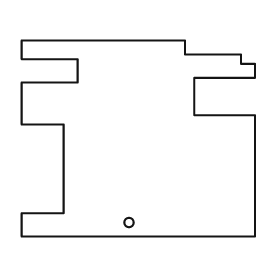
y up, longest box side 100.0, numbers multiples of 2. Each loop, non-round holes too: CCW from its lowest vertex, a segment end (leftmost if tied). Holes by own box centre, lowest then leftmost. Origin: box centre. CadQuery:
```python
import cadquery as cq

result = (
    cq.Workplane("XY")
    .moveTo(-50.0, -42.0)
    .lineTo(50.0, -42.0)
    .lineTo(50.0, 10.0)
    .lineTo(24.0, 10.0)
    .lineTo(24.0, 26.0)
    .lineTo(50.0, 26.0)
    .lineTo(50.0, 32.0)
    .lineTo(44.0, 32.0)
    .lineTo(44.0, 36.0)
    .lineTo(20.0, 36.0)
    .lineTo(20.0, 42.0)
    .lineTo(-50.0, 42.0)
    .lineTo(-50.0, 34.0)
    .lineTo(-26.0, 34.0)
    .lineTo(-26.0, 24.0)
    .lineTo(-50.0, 24.0)
    .lineTo(-50.0, 6.0)
    .lineTo(-32.0, 6.0)
    .lineTo(-32.0, -32.0)
    .lineTo(-50.0, -32.0)
    .close()
    .moveTo(-4.0, -36.0)
    .circle(2.0)
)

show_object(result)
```